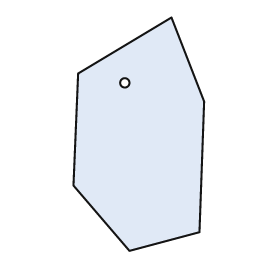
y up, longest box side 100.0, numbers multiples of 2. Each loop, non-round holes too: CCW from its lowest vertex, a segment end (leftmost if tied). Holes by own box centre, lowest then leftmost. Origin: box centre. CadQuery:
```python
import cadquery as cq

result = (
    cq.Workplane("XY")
    .moveTo(-4.0, -50.0)
    .lineTo(26.0, -42.0)
    .lineTo(28.0, 14.0)
    .lineTo(14.0, 50.0)
    .lineTo(-26.0, 26.0)
    .lineTo(-28.0, -22.0)
    .close()
    .moveTo(-6.0, 22.0)
    .circle(2.0)
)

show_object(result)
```